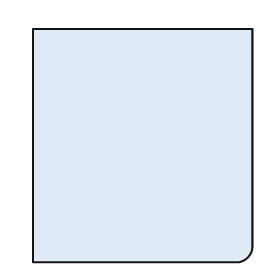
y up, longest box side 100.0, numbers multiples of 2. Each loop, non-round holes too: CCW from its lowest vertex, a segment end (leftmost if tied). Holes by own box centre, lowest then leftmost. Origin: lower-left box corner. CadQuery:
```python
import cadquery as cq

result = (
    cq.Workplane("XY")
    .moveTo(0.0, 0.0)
    .lineTo(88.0, 0.0)
    .threePointArc((92.0, 2.0), (94.0, 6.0))
    .lineTo(94.0, 100.0)
    .lineTo(0.0, 100.0)
    .close()
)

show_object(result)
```